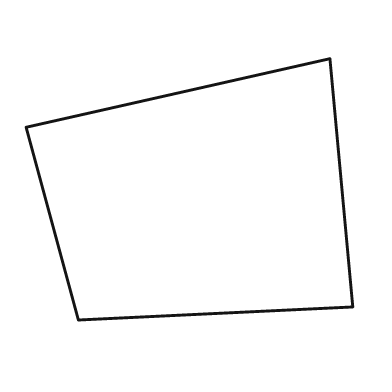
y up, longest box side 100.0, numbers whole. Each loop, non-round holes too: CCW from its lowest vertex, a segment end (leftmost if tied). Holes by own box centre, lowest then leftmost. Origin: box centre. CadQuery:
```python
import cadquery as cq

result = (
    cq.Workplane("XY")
    .moveTo(-34.0, -40.0)
    .lineTo(50.0, -36.0)
    .lineTo(43.0, 40.0)
    .lineTo(-50.0, 19.0)
    .close()
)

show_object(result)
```